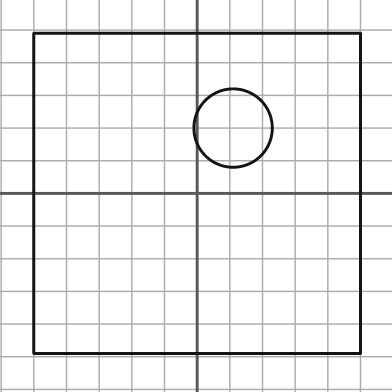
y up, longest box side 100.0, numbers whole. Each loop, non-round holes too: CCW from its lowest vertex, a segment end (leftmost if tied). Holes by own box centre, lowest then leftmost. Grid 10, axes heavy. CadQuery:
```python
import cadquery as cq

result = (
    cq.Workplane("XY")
    .moveTo(-50.0, -49.0)
    .lineTo(50.0, -49.0)
    .lineTo(50.0, 49.0)
    .lineTo(-50.0, 49.0)
    .close()
    .moveTo(11.0, 20.0)
    .circle(12.0)
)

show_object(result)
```